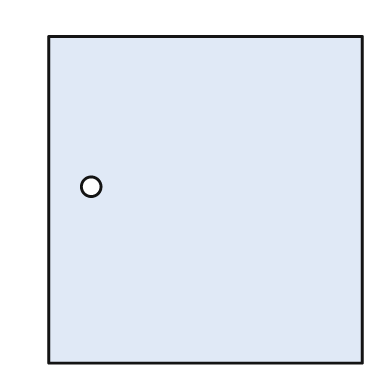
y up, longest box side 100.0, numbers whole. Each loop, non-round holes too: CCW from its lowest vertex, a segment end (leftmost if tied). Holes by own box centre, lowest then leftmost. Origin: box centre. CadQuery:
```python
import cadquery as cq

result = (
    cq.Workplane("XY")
    .moveTo(-48.0, -50.0)
    .lineTo(48.0, -50.0)
    .lineTo(48.0, 50.0)
    .lineTo(-48.0, 50.0)
    .close()
    .moveTo(-35.0, 4.0)
    .circle(3.0)
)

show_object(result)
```